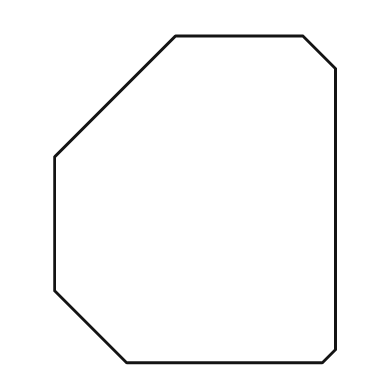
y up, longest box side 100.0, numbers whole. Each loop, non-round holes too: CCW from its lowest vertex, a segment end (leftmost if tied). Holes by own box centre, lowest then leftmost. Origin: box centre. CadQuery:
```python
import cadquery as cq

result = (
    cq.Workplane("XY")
    .moveTo(-21.0, -50.0)
    .lineTo(39.0, -50.0)
    .lineTo(43.0, -46.0)
    .lineTo(43.0, 40.0)
    .lineTo(33.0, 50.0)
    .lineTo(-6.0, 50.0)
    .lineTo(-43.0, 13.0)
    .lineTo(-43.0, -28.0)
    .close()
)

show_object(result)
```